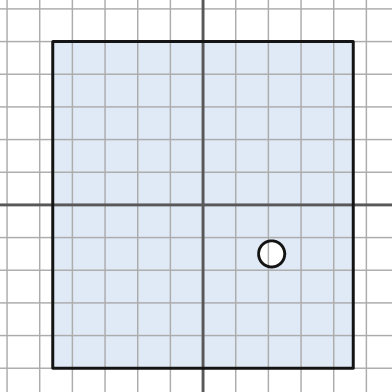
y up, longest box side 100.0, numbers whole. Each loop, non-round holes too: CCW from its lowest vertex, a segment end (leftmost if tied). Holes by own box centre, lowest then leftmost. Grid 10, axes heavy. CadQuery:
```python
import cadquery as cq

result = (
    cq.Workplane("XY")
    .moveTo(-46.0, -50.0)
    .lineTo(46.0, -50.0)
    .lineTo(46.0, 50.0)
    .lineTo(-46.0, 50.0)
    .close()
    .moveTo(21.0, -15.0)
    .circle(4.0)
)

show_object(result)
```